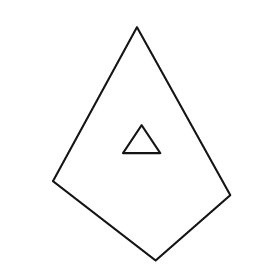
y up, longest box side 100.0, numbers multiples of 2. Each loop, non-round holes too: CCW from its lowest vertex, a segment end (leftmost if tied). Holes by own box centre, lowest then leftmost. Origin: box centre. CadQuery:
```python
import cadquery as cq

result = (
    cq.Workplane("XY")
    .moveTo(6.0, -50.0)
    .lineTo(38.0, -22.0)
    .lineTo(-2.0, 50.0)
    .lineTo(-38.0, -16.0)
    .close()
    .moveTo(-8.0, -4.0)
    .lineTo(8.0, -4.0)
    .lineTo(0.0, 8.0)
    .close()
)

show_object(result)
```